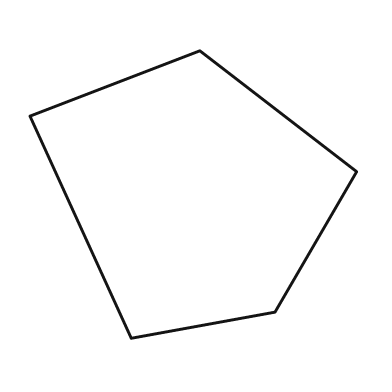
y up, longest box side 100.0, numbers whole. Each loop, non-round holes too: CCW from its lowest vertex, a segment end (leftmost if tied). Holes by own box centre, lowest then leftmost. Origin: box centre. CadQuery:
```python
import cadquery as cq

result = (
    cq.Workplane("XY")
    .moveTo(-19.0, -44.0)
    .lineTo(25.0, -36.0)
    .lineTo(50.0, 7.0)
    .lineTo(2.0, 44.0)
    .lineTo(-50.0, 24.0)
    .close()
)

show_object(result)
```